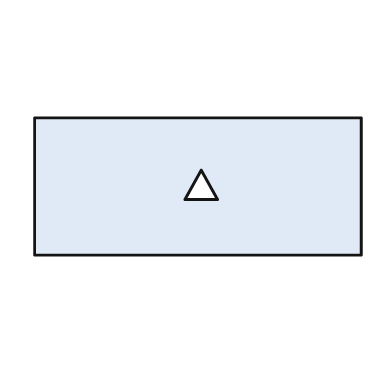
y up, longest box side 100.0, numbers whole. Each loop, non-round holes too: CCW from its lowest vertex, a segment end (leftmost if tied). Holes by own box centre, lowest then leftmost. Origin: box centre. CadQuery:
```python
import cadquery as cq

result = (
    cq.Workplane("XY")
    .moveTo(-50.0, -21.0)
    .lineTo(50.0, -21.0)
    .lineTo(50.0, 21.0)
    .lineTo(-50.0, 21.0)
    .close()
    .moveTo(-4.0, -4.0)
    .lineTo(6.0, -4.0)
    .lineTo(1.0, 5.0)
    .close()
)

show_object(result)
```